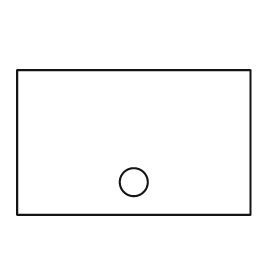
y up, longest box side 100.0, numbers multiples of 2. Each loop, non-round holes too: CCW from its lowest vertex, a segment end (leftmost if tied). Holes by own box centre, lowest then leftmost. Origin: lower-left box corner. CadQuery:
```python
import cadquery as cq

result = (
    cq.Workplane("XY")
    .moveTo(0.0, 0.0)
    .lineTo(100.0, 0.0)
    .lineTo(100.0, 62.0)
    .lineTo(0.0, 62.0)
    .close()
    .moveTo(50.0, 14.0)
    .circle(6.0)
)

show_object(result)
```